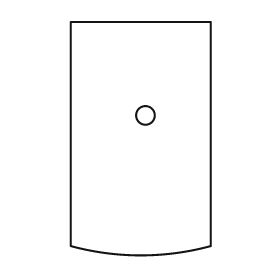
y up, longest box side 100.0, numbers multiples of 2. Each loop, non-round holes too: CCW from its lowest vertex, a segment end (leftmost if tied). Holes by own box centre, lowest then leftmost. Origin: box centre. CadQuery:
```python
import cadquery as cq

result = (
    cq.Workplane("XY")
    .moveTo(-30.0, -46.0)
    .threePointArc((0.0, -50.0), (30.0, -46.0))
    .lineTo(30.0, 50.0)
    .lineTo(-30.0, 50.0)
    .close()
    .moveTo(2.0, 10.0)
    .circle(4.0)
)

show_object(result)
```